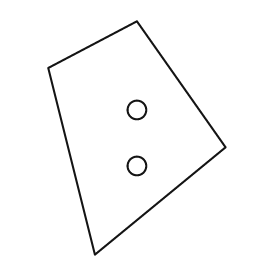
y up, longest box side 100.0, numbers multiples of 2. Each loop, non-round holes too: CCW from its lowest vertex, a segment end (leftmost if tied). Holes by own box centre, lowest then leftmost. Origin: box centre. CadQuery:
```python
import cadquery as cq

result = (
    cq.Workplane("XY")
    .moveTo(-18.0, -50.0)
    .lineTo(38.0, -4.0)
    .lineTo(0.0, 50.0)
    .lineTo(-38.0, 30.0)
    .close()
    .moveTo(0.0, -12.0)
    .circle(4.0)
    .moveTo(0.0, 12.0)
    .circle(4.0)
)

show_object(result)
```